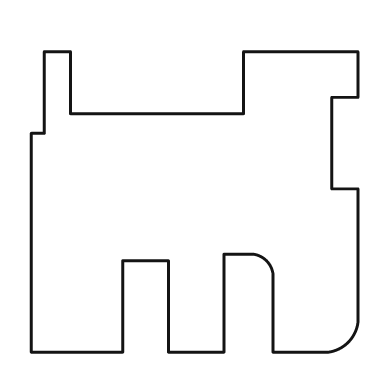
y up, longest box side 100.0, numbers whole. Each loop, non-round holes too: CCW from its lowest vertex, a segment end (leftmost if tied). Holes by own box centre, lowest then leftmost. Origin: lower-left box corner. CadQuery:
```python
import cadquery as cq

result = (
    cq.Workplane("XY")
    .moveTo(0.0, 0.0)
    .lineTo(28.0, 0.0)
    .lineTo(28.0, 28.0)
    .lineTo(42.0, 28.0)
    .lineTo(42.0, 0.0)
    .lineTo(59.0, 0.0)
    .lineTo(59.0, 30.0)
    .lineTo(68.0, 30.0)
    .threePointArc((72.0, 28.0), (74.0, 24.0))
    .lineTo(74.0, 0.0)
    .lineTo(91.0, 0.0)
    .threePointArc((97.0, 3.0), (100.0, 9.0))
    .lineTo(100.0, 50.0)
    .lineTo(92.0, 50.0)
    .lineTo(92.0, 78.0)
    .lineTo(100.0, 78.0)
    .lineTo(100.0, 92.0)
    .lineTo(65.0, 92.0)
    .lineTo(65.0, 73.0)
    .lineTo(12.0, 73.0)
    .lineTo(12.0, 92.0)
    .lineTo(4.0, 92.0)
    .lineTo(4.0, 67.0)
    .lineTo(0.0, 67.0)
    .close()
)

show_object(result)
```